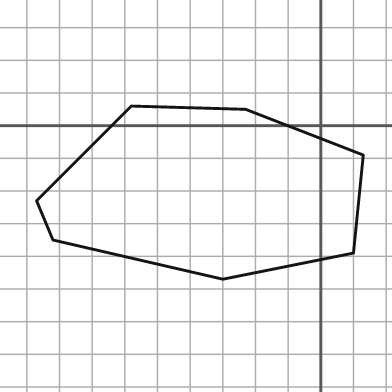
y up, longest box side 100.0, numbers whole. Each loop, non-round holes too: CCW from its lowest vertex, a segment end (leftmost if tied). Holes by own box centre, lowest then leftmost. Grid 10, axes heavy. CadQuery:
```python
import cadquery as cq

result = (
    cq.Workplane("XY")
    .moveTo(-30.0, -47.0)
    .lineTo(10.0, -39.0)
    .lineTo(13.0, -9.0)
    .lineTo(-23.0, 5.0)
    .lineTo(-58.0, 6.0)
    .lineTo(-87.0, -23.0)
    .lineTo(-82.0, -35.0)
    .close()
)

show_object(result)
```